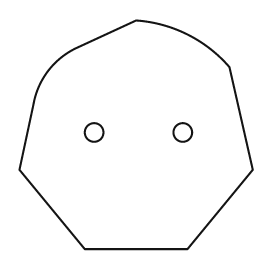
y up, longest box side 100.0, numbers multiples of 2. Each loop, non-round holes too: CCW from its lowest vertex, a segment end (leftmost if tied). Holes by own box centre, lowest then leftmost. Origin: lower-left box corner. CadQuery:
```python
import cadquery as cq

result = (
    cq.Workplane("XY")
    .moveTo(28.0, 0.0)
    .lineTo(72.0, 0.0)
    .lineTo(100.0, 34.0)
    .lineTo(90.0, 78.0)
    .threePointArc((72.0, 92.0), (50.0, 98.0))
    .lineTo(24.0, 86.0)
    .threePointArc((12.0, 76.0), (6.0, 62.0))
    .lineTo(0.0, 34.0)
    .close()
    .moveTo(32.0, 50.0)
    .circle(4.0)
    .moveTo(70.0, 50.0)
    .circle(4.0)
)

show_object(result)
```